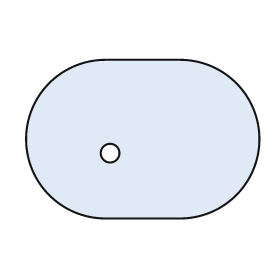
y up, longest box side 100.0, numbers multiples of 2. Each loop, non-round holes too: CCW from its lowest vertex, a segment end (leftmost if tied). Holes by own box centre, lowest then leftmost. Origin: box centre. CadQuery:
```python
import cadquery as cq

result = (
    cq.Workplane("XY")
    .moveTo(-16.0, -34.0)
    .lineTo(16.0, -34.0)
    .threePointArc((50.0, 0.0), (16.0, 34.0))
    .lineTo(-16.0, 34.0)
    .threePointArc((-50.0, 0.0), (-16.0, -34.0))
    .close()
    .moveTo(-14.0, -6.0)
    .circle(4.0)
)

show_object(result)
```